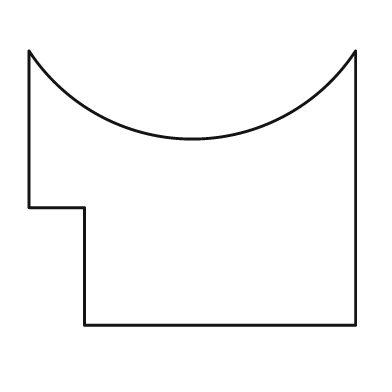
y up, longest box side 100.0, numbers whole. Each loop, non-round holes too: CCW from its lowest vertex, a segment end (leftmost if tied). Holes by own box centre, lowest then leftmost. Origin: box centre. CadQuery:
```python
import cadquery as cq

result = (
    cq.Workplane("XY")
    .moveTo(-33.0, -42.0)
    .lineTo(50.0, -42.0)
    .lineTo(50.0, 42.0)
    .threePointArc((0.0, 15.0), (-50.0, 42.0))
    .lineTo(-50.0, -6.0)
    .lineTo(-33.0, -6.0)
    .close()
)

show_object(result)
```